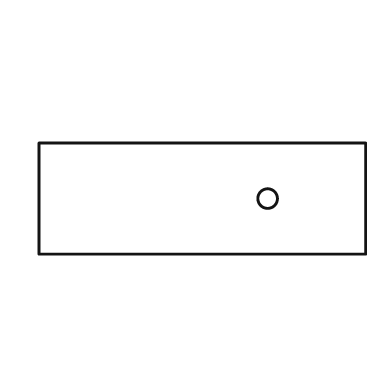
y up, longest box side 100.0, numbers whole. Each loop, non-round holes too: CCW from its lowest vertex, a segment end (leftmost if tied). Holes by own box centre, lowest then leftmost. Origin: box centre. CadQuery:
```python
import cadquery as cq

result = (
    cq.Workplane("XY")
    .moveTo(-50.0, -17.0)
    .lineTo(50.0, -17.0)
    .lineTo(50.0, 17.0)
    .lineTo(-50.0, 17.0)
    .close()
    .moveTo(20.0, 0.0)
    .circle(3.0)
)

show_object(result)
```